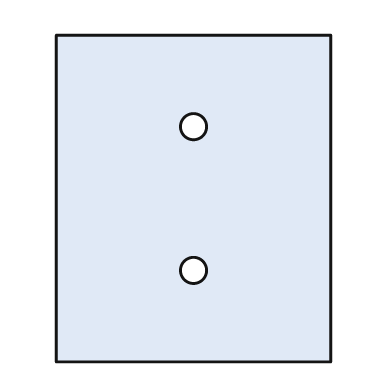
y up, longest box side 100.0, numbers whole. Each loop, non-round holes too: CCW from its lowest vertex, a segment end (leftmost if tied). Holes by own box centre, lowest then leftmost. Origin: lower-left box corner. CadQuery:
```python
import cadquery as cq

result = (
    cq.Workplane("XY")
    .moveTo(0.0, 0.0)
    .lineTo(84.0, 0.0)
    .lineTo(84.0, 100.0)
    .lineTo(0.0, 100.0)
    .close()
    .moveTo(42.0, 28.0)
    .circle(4.0)
    .moveTo(42.0, 72.0)
    .circle(4.0)
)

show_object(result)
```